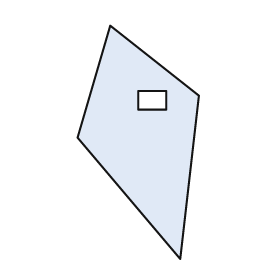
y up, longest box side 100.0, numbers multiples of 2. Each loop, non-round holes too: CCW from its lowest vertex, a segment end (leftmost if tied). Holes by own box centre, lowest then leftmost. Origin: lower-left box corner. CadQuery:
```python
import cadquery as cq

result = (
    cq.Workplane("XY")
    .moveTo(44.0, 0.0)
    .lineTo(52.0, 70.0)
    .lineTo(14.0, 100.0)
    .lineTo(0.0, 52.0)
    .close()
    .moveTo(26.0, 64.0)
    .lineTo(38.0, 64.0)
    .lineTo(38.0, 72.0)
    .lineTo(26.0, 72.0)
    .close()
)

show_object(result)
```